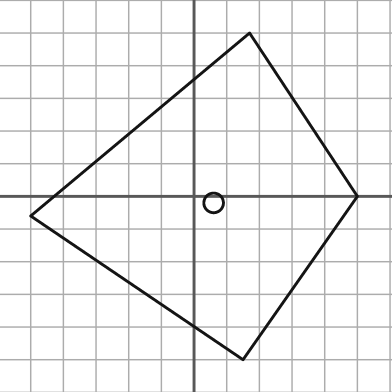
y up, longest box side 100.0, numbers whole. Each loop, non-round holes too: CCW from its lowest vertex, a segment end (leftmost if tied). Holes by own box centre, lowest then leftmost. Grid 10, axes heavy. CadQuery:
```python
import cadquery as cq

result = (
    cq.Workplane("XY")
    .moveTo(15.0, -50.0)
    .lineTo(50.0, 0.0)
    .lineTo(17.0, 50.0)
    .lineTo(-50.0, -6.0)
    .close()
    .moveTo(6.0, -2.0)
    .circle(3.0)
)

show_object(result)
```